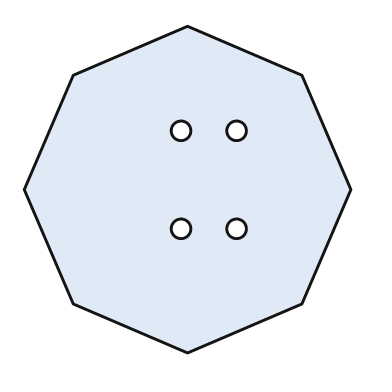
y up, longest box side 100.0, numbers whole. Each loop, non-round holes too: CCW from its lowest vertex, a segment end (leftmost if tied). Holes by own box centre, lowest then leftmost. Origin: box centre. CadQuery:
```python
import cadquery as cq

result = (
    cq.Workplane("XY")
    .moveTo(0.0, -50.0)
    .lineTo(35.0, -35.0)
    .lineTo(50.0, 0.0)
    .lineTo(35.0, 35.0)
    .lineTo(0.0, 50.0)
    .lineTo(-35.0, 35.0)
    .lineTo(-50.0, 0.0)
    .lineTo(-35.0, -35.0)
    .close()
    .moveTo(-2.0, -12.0)
    .circle(3.0)
    .moveTo(15.0, -12.0)
    .circle(3.0)
    .moveTo(-2.0, 18.0)
    .circle(3.0)
    .moveTo(15.0, 18.0)
    .circle(3.0)
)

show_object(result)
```